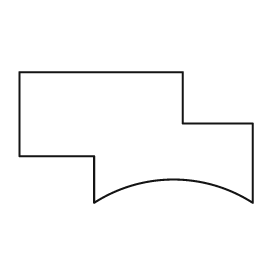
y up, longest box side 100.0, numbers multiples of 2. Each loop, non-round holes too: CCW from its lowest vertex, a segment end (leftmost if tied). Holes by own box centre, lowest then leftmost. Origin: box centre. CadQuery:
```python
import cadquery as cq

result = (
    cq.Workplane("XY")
    .moveTo(-18.0, -28.0)
    .threePointArc((16.0, -18.0), (50.0, -28.0))
    .lineTo(50.0, 6.0)
    .lineTo(20.0, 6.0)
    .lineTo(20.0, 28.0)
    .lineTo(-50.0, 28.0)
    .lineTo(-50.0, -8.0)
    .lineTo(-18.0, -8.0)
    .close()
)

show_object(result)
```